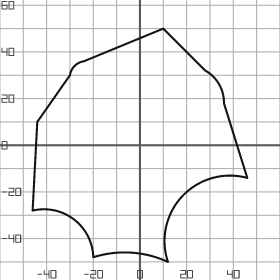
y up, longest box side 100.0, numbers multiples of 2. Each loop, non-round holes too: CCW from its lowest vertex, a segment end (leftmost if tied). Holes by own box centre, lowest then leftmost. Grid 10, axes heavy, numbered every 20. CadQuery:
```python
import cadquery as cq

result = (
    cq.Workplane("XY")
    .moveTo(12.0, -50.0)
    .threePointArc((18.0, -22.0), (46.0, -14.0))
    .lineTo(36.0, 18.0)
    .threePointArc((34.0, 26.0), (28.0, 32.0))
    .lineTo(10.0, 50.0)
    .lineTo(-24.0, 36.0)
    .threePointArc((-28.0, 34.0), (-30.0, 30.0))
    .lineTo(-44.0, 10.0)
    .lineTo(-46.0, -28.0)
    .threePointArc((-28.0, -32.0), (-20.0, -48.0))
    .threePointArc((-4.0, -46.0), (12.0, -50.0))
    .close()
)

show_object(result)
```